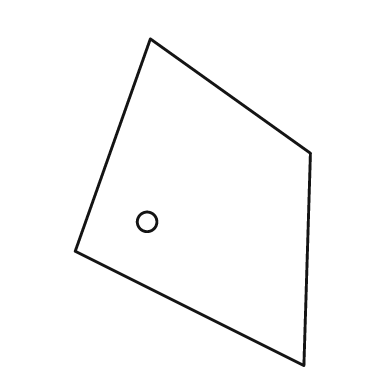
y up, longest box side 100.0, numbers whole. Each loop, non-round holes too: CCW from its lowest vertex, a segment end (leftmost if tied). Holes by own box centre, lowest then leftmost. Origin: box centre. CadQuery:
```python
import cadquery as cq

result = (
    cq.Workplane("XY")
    .moveTo(34.0, -50.0)
    .lineTo(36.0, 15.0)
    .lineTo(-13.0, 50.0)
    .lineTo(-36.0, -15.0)
    .close()
    .moveTo(-14.0, -6.0)
    .circle(3.0)
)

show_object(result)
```